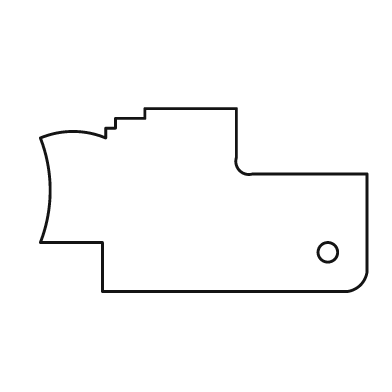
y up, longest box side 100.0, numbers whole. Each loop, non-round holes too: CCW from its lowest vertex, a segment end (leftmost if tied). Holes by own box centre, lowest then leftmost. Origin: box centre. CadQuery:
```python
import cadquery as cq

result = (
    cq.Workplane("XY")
    .moveTo(-31.0, -28.0)
    .lineTo(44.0, -28.0)
    .threePointArc((48.0, -26.0), (50.0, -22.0))
    .lineTo(50.0, 8.0)
    .lineTo(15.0, 8.0)
    .threePointArc((11.0, 9.0), (10.0, 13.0))
    .lineTo(10.0, 28.0)
    .lineTo(-18.0, 28.0)
    .lineTo(-18.0, 25.0)
    .lineTo(-27.0, 25.0)
    .lineTo(-27.0, 22.0)
    .lineTo(-30.0, 22.0)
    .lineTo(-30.0, 19.0)
    .threePointArc((-40.0, 21.0), (-50.0, 19.0))
    .threePointArc((-47.0, 3.0), (-50.0, -13.0))
    .lineTo(-31.0, -13.0)
    .close()
    .moveTo(38.0, -16.0)
    .circle(3.0)
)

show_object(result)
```